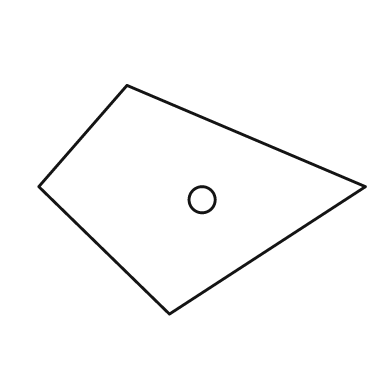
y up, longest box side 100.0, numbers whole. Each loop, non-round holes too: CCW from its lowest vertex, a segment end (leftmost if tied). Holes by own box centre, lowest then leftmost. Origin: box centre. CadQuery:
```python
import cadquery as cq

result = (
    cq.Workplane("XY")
    .moveTo(-10.0, -35.0)
    .lineTo(50.0, 4.0)
    .lineTo(-23.0, 35.0)
    .lineTo(-50.0, 4.0)
    .close()
    .moveTo(0.0, 0.0)
    .circle(4.0)
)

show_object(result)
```